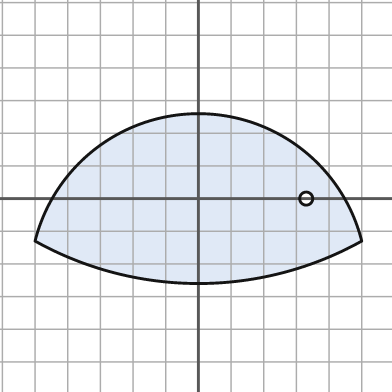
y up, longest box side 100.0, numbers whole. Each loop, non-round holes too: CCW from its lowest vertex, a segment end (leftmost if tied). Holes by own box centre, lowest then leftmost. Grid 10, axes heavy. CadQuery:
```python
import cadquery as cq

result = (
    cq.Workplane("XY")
    .moveTo(-50.0, -13.0)
    .threePointArc((0.0, -26.0), (50.0, -13.0))
    .threePointArc((0.0, 26.0), (-50.0, -13.0))
    .close()
    .moveTo(33.0, 0.0)
    .circle(2.0)
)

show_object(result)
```